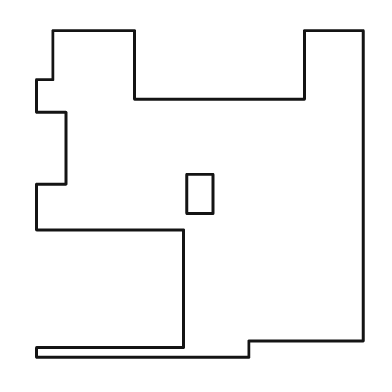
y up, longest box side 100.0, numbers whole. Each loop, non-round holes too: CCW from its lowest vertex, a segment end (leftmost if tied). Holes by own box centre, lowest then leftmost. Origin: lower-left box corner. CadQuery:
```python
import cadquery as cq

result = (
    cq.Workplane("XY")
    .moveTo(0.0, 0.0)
    .lineTo(65.0, 0.0)
    .lineTo(65.0, 5.0)
    .lineTo(100.0, 5.0)
    .lineTo(100.0, 100.0)
    .lineTo(82.0, 100.0)
    .lineTo(82.0, 79.0)
    .lineTo(30.0, 79.0)
    .lineTo(30.0, 100.0)
    .lineTo(5.0, 100.0)
    .lineTo(5.0, 85.0)
    .lineTo(0.0, 85.0)
    .lineTo(0.0, 75.0)
    .lineTo(9.0, 75.0)
    .lineTo(9.0, 53.0)
    .lineTo(0.0, 53.0)
    .lineTo(0.0, 39.0)
    .lineTo(45.0, 39.0)
    .lineTo(45.0, 3.0)
    .lineTo(0.0, 3.0)
    .close()
    .moveTo(46.0, 44.0)
    .lineTo(54.0, 44.0)
    .lineTo(54.0, 56.0)
    .lineTo(46.0, 56.0)
    .close()
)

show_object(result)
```